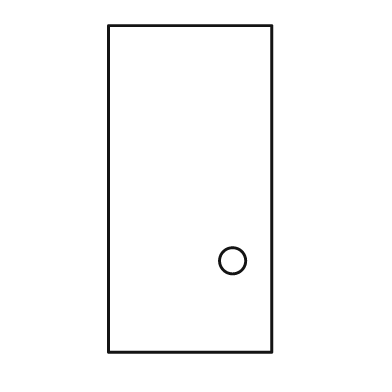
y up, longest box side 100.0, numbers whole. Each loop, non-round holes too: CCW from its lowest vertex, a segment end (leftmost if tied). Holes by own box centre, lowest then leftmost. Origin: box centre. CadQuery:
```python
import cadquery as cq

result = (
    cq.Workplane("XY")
    .moveTo(-25.0, -50.0)
    .lineTo(25.0, -50.0)
    .lineTo(25.0, 50.0)
    .lineTo(-25.0, 50.0)
    .close()
    .moveTo(13.0, -22.0)
    .circle(4.0)
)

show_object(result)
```